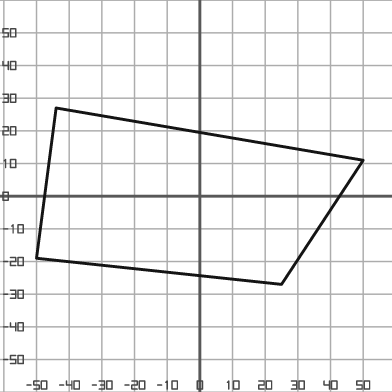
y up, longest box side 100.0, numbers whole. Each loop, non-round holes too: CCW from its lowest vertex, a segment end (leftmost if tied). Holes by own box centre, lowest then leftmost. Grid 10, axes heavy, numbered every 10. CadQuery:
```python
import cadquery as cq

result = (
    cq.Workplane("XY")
    .moveTo(25.0, -27.0)
    .lineTo(50.0, 11.0)
    .lineTo(-44.0, 27.0)
    .lineTo(-50.0, -19.0)
    .close()
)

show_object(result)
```